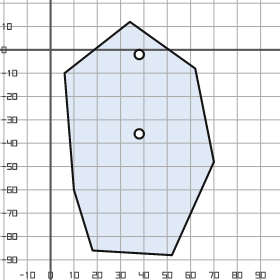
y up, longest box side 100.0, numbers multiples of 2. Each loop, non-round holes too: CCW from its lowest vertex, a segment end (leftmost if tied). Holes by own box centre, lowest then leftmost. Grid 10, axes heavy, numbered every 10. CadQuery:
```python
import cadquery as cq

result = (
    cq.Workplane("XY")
    .moveTo(52.0, -88.0)
    .lineTo(70.0, -48.0)
    .lineTo(62.0, -8.0)
    .lineTo(34.0, 12.0)
    .lineTo(6.0, -10.0)
    .lineTo(10.0, -60.0)
    .lineTo(18.0, -86.0)
    .close()
    .moveTo(38.0, -36.0)
    .circle(2.0)
    .moveTo(38.0, -2.0)
    .circle(2.0)
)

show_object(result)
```